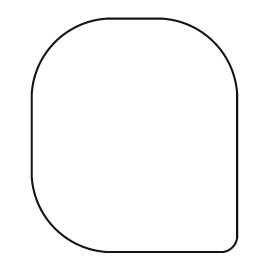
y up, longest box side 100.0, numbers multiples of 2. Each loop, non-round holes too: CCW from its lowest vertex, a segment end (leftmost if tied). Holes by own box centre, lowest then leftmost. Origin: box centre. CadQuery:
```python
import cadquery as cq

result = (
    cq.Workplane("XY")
    .moveTo(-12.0, -50.0)
    .lineTo(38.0, -50.0)
    .threePointArc((42.0, -48.0), (44.0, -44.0))
    .lineTo(44.0, 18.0)
    .threePointArc((34.0, 40.0), (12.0, 50.0))
    .lineTo(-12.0, 50.0)
    .threePointArc((-34.0, 40.0), (-44.0, 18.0))
    .lineTo(-44.0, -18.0)
    .threePointArc((-34.0, -40.0), (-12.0, -50.0))
    .close()
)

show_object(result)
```